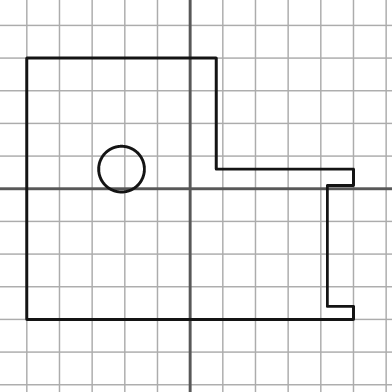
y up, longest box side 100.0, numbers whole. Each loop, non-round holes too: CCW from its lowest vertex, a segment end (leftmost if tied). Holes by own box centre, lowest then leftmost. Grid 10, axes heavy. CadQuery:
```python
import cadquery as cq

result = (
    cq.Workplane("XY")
    .moveTo(-50.0, -40.0)
    .lineTo(50.0, -40.0)
    .lineTo(50.0, -36.0)
    .lineTo(42.0, -36.0)
    .lineTo(42.0, 1.0)
    .lineTo(50.0, 1.0)
    .lineTo(50.0, 6.0)
    .lineTo(8.0, 6.0)
    .lineTo(8.0, 40.0)
    .lineTo(-50.0, 40.0)
    .close()
    .moveTo(-21.0, 6.0)
    .circle(7.0)
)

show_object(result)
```